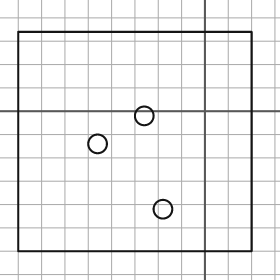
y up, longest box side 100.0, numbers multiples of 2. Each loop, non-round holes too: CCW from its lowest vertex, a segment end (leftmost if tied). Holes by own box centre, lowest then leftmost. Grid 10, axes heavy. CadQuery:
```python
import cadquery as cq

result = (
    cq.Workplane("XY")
    .moveTo(-80.0, -60.0)
    .lineTo(20.0, -60.0)
    .lineTo(20.0, 34.0)
    .lineTo(-80.0, 34.0)
    .close()
    .moveTo(-18.0, -42.0)
    .circle(4.0)
    .moveTo(-46.0, -14.0)
    .circle(4.0)
    .moveTo(-26.0, -2.0)
    .circle(4.0)
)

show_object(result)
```